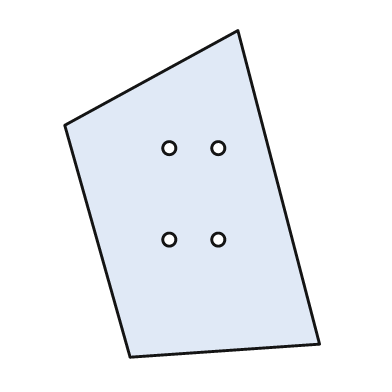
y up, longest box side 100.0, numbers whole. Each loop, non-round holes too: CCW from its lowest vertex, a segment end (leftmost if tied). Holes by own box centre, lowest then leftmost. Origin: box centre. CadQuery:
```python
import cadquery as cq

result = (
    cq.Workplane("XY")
    .moveTo(-19.0, -50.0)
    .lineTo(39.0, -46.0)
    .lineTo(14.0, 50.0)
    .lineTo(-39.0, 21.0)
    .close()
    .moveTo(-7.0, -14.0)
    .circle(2.0)
    .moveTo(8.0, -14.0)
    .circle(2.0)
    .moveTo(-7.0, 14.0)
    .circle(2.0)
    .moveTo(8.0, 14.0)
    .circle(2.0)
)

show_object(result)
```